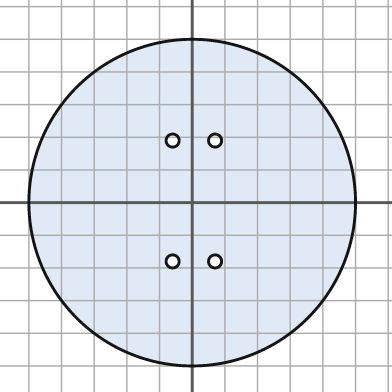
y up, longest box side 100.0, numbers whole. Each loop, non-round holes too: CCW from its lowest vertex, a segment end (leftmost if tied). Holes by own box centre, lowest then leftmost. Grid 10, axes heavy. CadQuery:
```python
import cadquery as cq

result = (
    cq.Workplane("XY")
    .moveTo(0.0, 0.0)
    .circle(50.0)
    .moveTo(-6.0, -18.0)
    .circle(2.0)
    .moveTo(7.0, -18.0)
    .circle(2.0)
    .moveTo(-6.0, 19.0)
    .circle(2.0)
    .moveTo(7.0, 19.0)
    .circle(2.0)
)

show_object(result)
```